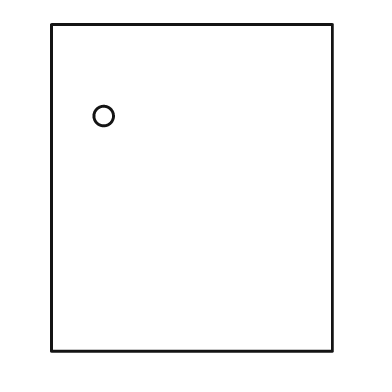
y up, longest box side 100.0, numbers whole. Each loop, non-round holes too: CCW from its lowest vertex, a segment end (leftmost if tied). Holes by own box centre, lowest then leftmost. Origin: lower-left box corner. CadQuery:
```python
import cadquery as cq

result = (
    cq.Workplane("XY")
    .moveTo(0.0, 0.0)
    .lineTo(86.0, 0.0)
    .lineTo(86.0, 100.0)
    .lineTo(0.0, 100.0)
    .close()
    .moveTo(16.0, 72.0)
    .circle(3.0)
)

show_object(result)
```